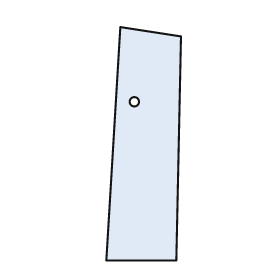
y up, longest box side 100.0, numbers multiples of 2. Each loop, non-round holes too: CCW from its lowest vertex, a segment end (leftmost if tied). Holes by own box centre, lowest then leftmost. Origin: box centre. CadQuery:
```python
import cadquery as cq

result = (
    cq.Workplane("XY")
    .moveTo(-16.0, -50.0)
    .lineTo(14.0, -50.0)
    .lineTo(16.0, 46.0)
    .lineTo(-10.0, 50.0)
    .close()
    .moveTo(-4.0, 18.0)
    .circle(2.0)
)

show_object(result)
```